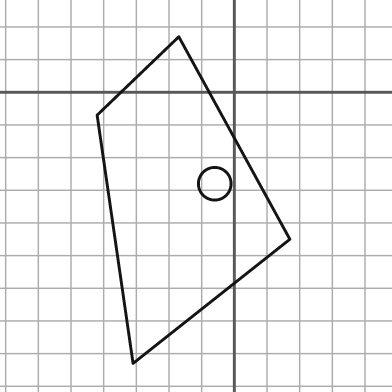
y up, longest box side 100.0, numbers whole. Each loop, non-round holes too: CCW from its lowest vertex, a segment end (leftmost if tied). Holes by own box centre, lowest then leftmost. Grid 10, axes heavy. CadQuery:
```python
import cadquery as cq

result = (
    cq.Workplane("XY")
    .moveTo(-31.0, -83.0)
    .lineTo(17.0, -45.0)
    .lineTo(-17.0, 17.0)
    .lineTo(-42.0, -7.0)
    .close()
    .moveTo(-6.0, -28.0)
    .circle(5.0)
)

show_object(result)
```